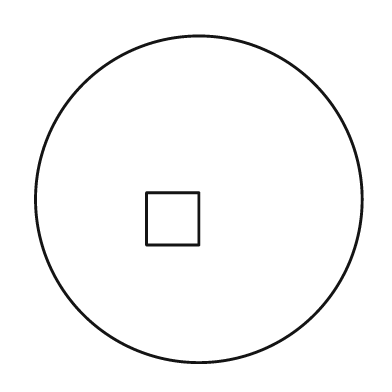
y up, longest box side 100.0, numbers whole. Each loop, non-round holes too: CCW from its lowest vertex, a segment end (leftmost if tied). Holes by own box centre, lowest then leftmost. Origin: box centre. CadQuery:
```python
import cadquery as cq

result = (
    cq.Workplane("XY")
    .moveTo(0.0, 0.0)
    .circle(50.0)
    .moveTo(-16.0, -14.0)
    .lineTo(0.0, -14.0)
    .lineTo(0.0, 2.0)
    .lineTo(-16.0, 2.0)
    .close()
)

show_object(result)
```